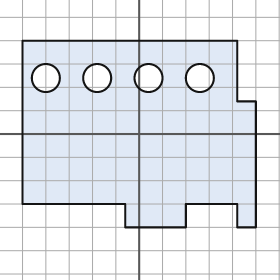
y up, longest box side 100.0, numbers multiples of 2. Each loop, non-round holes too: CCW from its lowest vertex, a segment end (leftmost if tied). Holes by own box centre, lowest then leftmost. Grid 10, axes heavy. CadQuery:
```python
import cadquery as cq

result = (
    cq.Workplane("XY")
    .moveTo(-6.0, -40.0)
    .lineTo(20.0, -40.0)
    .lineTo(20.0, -30.0)
    .lineTo(42.0, -30.0)
    .lineTo(42.0, -40.0)
    .lineTo(50.0, -40.0)
    .lineTo(50.0, 14.0)
    .lineTo(42.0, 14.0)
    .lineTo(42.0, 40.0)
    .lineTo(-50.0, 40.0)
    .lineTo(-50.0, -30.0)
    .lineTo(-6.0, -30.0)
    .close()
    .moveTo(-40.0, 24.0)
    .circle(6.0)
    .moveTo(-18.0, 24.0)
    .circle(6.0)
    .moveTo(4.0, 24.0)
    .circle(6.0)
    .moveTo(26.0, 24.0)
    .circle(6.0)
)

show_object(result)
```